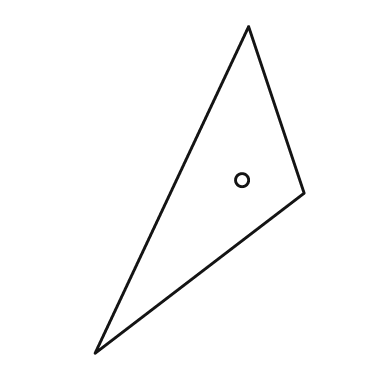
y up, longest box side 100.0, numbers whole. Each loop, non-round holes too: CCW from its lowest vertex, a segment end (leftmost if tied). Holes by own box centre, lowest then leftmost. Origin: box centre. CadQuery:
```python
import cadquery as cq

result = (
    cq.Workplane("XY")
    .moveTo(-32.0, -50.0)
    .lineTo(32.0, -1.0)
    .lineTo(15.0, 50.0)
    .close()
    .moveTo(13.0, 3.0)
    .circle(2.0)
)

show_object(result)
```